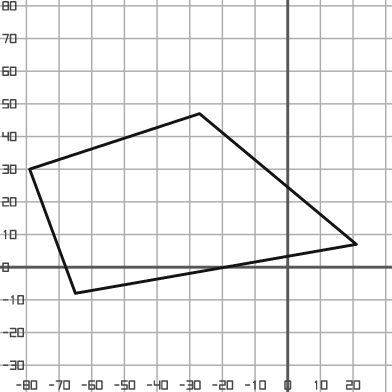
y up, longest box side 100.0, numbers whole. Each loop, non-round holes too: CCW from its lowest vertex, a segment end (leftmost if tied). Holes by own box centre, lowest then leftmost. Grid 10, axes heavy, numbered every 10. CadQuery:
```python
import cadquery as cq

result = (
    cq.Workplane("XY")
    .moveTo(-65.0, -8.0)
    .lineTo(21.0, 7.0)
    .lineTo(-27.0, 47.0)
    .lineTo(-79.0, 30.0)
    .close()
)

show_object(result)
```